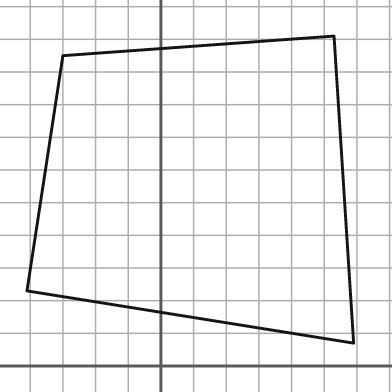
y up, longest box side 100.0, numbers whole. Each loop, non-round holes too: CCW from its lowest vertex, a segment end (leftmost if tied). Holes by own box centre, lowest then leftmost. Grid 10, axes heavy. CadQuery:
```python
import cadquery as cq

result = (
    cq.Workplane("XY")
    .moveTo(59.0, 7.0)
    .lineTo(53.0, 101.0)
    .lineTo(-30.0, 95.0)
    .lineTo(-41.0, 23.0)
    .close()
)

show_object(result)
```